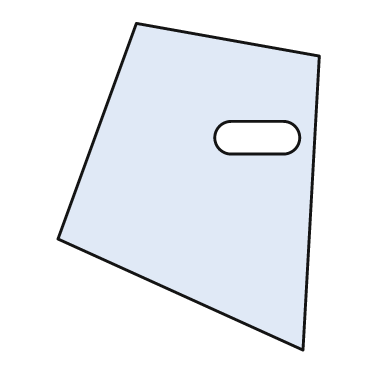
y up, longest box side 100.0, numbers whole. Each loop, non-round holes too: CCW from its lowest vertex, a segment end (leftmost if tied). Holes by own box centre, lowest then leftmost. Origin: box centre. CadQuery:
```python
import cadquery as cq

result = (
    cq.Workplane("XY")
    .moveTo(35.0, -50.0)
    .lineTo(40.0, 40.0)
    .lineTo(-16.0, 50.0)
    .lineTo(-40.0, -16.0)
    .close()
    .moveTo(13.0, 10.0)
    .lineTo(29.0, 10.0)
    .threePointArc((34.0, 15.0), (29.0, 20.0))
    .lineTo(13.0, 20.0)
    .threePointArc((8.0, 15.0), (13.0, 10.0))
    .close()
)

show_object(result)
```